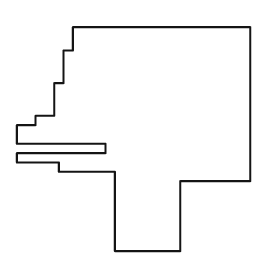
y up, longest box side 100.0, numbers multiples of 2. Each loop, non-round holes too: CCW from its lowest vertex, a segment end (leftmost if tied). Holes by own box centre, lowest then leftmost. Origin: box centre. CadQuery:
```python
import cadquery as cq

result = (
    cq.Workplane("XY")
    .moveTo(-8.0, -48.0)
    .lineTo(20.0, -48.0)
    .lineTo(20.0, -18.0)
    .lineTo(50.0, -18.0)
    .lineTo(50.0, 48.0)
    .lineTo(-26.0, 48.0)
    .lineTo(-26.0, 38.0)
    .lineTo(-30.0, 38.0)
    .lineTo(-30.0, 24.0)
    .lineTo(-34.0, 24.0)
    .lineTo(-34.0, 10.0)
    .lineTo(-42.0, 10.0)
    .lineTo(-42.0, 6.0)
    .lineTo(-50.0, 6.0)
    .lineTo(-50.0, -2.0)
    .lineTo(-12.0, -2.0)
    .lineTo(-12.0, -6.0)
    .lineTo(-50.0, -6.0)
    .lineTo(-50.0, -10.0)
    .lineTo(-32.0, -10.0)
    .lineTo(-32.0, -14.0)
    .lineTo(-8.0, -14.0)
    .close()
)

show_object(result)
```